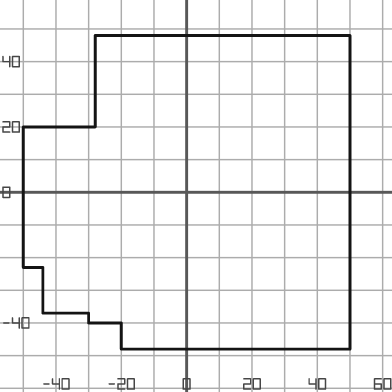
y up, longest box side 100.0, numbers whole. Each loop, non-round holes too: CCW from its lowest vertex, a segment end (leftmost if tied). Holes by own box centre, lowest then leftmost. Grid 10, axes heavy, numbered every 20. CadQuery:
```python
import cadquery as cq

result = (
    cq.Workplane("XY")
    .moveTo(-20.0, -48.0)
    .lineTo(50.0, -48.0)
    .lineTo(50.0, 48.0)
    .lineTo(-28.0, 48.0)
    .lineTo(-28.0, 20.0)
    .lineTo(-50.0, 20.0)
    .lineTo(-50.0, -23.0)
    .lineTo(-44.0, -23.0)
    .lineTo(-44.0, -37.0)
    .lineTo(-30.0, -37.0)
    .lineTo(-30.0, -40.0)
    .lineTo(-20.0, -40.0)
    .close()
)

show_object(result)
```